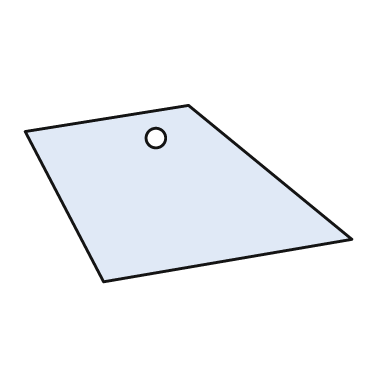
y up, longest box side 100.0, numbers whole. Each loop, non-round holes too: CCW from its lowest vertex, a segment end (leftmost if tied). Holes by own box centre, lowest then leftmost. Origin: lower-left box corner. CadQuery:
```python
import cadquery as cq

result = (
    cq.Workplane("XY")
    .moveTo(24.0, 0.0)
    .lineTo(100.0, 13.0)
    .lineTo(50.0, 54.0)
    .lineTo(0.0, 46.0)
    .close()
    .moveTo(40.0, 44.0)
    .circle(3.0)
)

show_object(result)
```